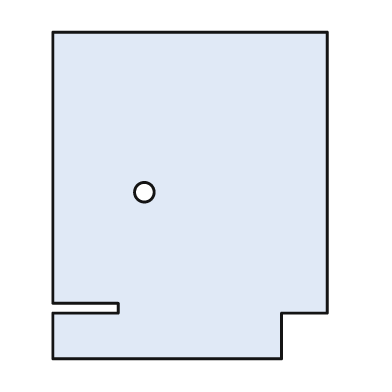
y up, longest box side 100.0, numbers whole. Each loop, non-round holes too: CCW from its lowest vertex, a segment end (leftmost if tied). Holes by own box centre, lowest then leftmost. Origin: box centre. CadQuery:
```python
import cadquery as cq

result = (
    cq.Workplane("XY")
    .moveTo(-42.0, -50.0)
    .lineTo(28.0, -50.0)
    .lineTo(28.0, -36.0)
    .lineTo(42.0, -36.0)
    .lineTo(42.0, 50.0)
    .lineTo(-42.0, 50.0)
    .lineTo(-42.0, -33.0)
    .lineTo(-22.0, -33.0)
    .lineTo(-22.0, -36.0)
    .lineTo(-42.0, -36.0)
    .close()
    .moveTo(-14.0, 1.0)
    .circle(3.0)
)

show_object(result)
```